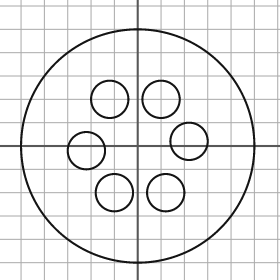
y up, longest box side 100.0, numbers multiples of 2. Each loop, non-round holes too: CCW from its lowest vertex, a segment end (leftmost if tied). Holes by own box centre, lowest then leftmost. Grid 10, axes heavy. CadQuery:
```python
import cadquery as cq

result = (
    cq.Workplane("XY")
    .moveTo(0.0, 0.0)
    .circle(50.0)
    .moveTo(-10.0, -20.0)
    .circle(8.0)
    .moveTo(12.0, -20.0)
    .circle(8.0)
    .moveTo(-22.0, -2.0)
    .circle(8.0)
    .moveTo(22.0, 2.0)
    .circle(8.0)
    .moveTo(-12.0, 20.0)
    .circle(8.0)
    .moveTo(10.0, 20.0)
    .circle(8.0)
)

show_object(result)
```